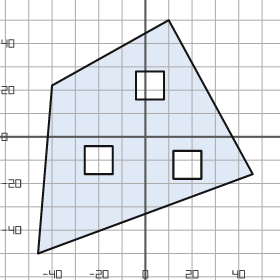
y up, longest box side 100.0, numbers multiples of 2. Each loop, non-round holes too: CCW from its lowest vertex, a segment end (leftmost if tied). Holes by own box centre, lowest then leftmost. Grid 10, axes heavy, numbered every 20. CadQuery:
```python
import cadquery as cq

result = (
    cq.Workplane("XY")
    .moveTo(-46.0, -50.0)
    .lineTo(46.0, -16.0)
    .lineTo(10.0, 50.0)
    .lineTo(-40.0, 22.0)
    .close()
    .moveTo(12.0, -18.0)
    .lineTo(24.0, -18.0)
    .lineTo(24.0, -6.0)
    .lineTo(12.0, -6.0)
    .close()
    .moveTo(-26.0, -16.0)
    .lineTo(-14.0, -16.0)
    .lineTo(-14.0, -4.0)
    .lineTo(-26.0, -4.0)
    .close()
    .moveTo(-4.0, 16.0)
    .lineTo(8.0, 16.0)
    .lineTo(8.0, 28.0)
    .lineTo(-4.0, 28.0)
    .close()
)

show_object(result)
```